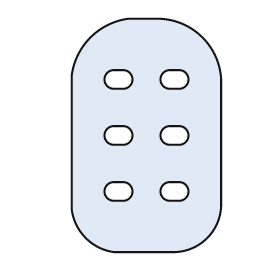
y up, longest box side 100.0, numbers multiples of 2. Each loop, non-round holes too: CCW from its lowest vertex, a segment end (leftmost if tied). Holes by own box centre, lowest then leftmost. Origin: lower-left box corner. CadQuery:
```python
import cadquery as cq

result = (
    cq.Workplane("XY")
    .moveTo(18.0, 0.0)
    .lineTo(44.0, 0.0)
    .threePointArc((58.0, 6.0), (64.0, 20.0))
    .lineTo(64.0, 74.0)
    .threePointArc((56.0, 92.0), (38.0, 100.0))
    .lineTo(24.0, 100.0)
    .threePointArc((8.0, 92.0), (0.0, 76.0))
    .lineTo(0.0, 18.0)
    .threePointArc((6.0, 6.0), (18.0, 0.0))
    .close()
    .moveTo(18.0, 22.0)
    .lineTo(22.0, 22.0)
    .threePointArc((26.0, 26.0), (22.0, 30.0))
    .lineTo(18.0, 30.0)
    .threePointArc((14.0, 26.0), (18.0, 22.0))
    .close()
    .moveTo(42.0, 22.0)
    .lineTo(46.0, 22.0)
    .threePointArc((50.0, 26.0), (46.0, 30.0))
    .lineTo(42.0, 30.0)
    .threePointArc((38.0, 26.0), (42.0, 22.0))
    .close()
    .moveTo(18.0, 46.0)
    .lineTo(22.0, 46.0)
    .threePointArc((26.0, 50.0), (22.0, 54.0))
    .lineTo(18.0, 54.0)
    .threePointArc((14.0, 50.0), (18.0, 46.0))
    .close()
    .moveTo(42.0, 46.0)
    .lineTo(46.0, 46.0)
    .threePointArc((50.0, 50.0), (46.0, 54.0))
    .lineTo(42.0, 54.0)
    .threePointArc((38.0, 50.0), (42.0, 46.0))
    .close()
    .moveTo(18.0, 70.0)
    .lineTo(22.0, 70.0)
    .threePointArc((26.0, 74.0), (22.0, 78.0))
    .lineTo(18.0, 78.0)
    .threePointArc((14.0, 74.0), (18.0, 70.0))
    .close()
    .moveTo(42.0, 70.0)
    .lineTo(46.0, 70.0)
    .threePointArc((50.0, 74.0), (46.0, 78.0))
    .lineTo(42.0, 78.0)
    .threePointArc((38.0, 74.0), (42.0, 70.0))
    .close()
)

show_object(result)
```